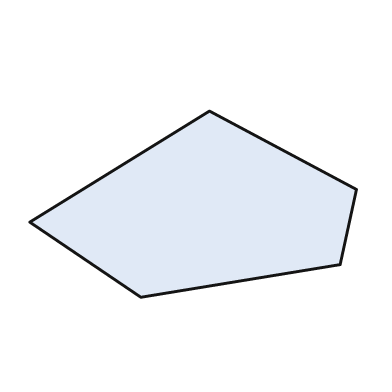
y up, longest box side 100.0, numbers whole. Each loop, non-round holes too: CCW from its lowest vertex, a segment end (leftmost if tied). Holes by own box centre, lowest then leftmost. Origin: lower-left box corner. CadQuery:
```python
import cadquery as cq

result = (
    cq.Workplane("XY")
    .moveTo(34.0, 0.0)
    .lineTo(95.0, 10.0)
    .lineTo(100.0, 33.0)
    .lineTo(55.0, 57.0)
    .lineTo(0.0, 23.0)
    .close()
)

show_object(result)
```